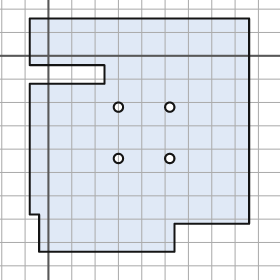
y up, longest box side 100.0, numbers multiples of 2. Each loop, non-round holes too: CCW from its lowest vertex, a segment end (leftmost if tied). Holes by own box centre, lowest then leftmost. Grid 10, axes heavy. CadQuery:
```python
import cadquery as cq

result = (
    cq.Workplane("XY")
    .moveTo(-4.0, -84.0)
    .lineTo(54.0, -84.0)
    .lineTo(54.0, -72.0)
    .lineTo(86.0, -72.0)
    .lineTo(86.0, 16.0)
    .lineTo(-8.0, 16.0)
    .lineTo(-8.0, -4.0)
    .lineTo(24.0, -4.0)
    .lineTo(24.0, -12.0)
    .lineTo(-8.0, -12.0)
    .lineTo(-8.0, -68.0)
    .lineTo(-4.0, -68.0)
    .close()
    .moveTo(30.0, -44.0)
    .circle(2.0)
    .moveTo(52.0, -44.0)
    .circle(2.0)
    .moveTo(30.0, -22.0)
    .circle(2.0)
    .moveTo(52.0, -22.0)
    .circle(2.0)
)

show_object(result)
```